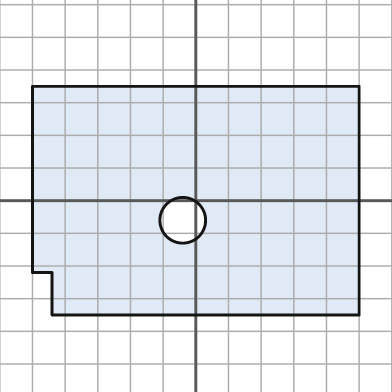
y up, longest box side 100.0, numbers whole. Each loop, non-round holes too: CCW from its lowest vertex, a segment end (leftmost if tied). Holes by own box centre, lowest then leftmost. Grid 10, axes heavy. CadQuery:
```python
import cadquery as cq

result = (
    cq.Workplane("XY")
    .moveTo(-44.0, -35.0)
    .lineTo(50.0, -35.0)
    .lineTo(50.0, 35.0)
    .lineTo(-50.0, 35.0)
    .lineTo(-50.0, -22.0)
    .lineTo(-44.0, -22.0)
    .close()
    .moveTo(-4.0, -6.0)
    .circle(7.0)
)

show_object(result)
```